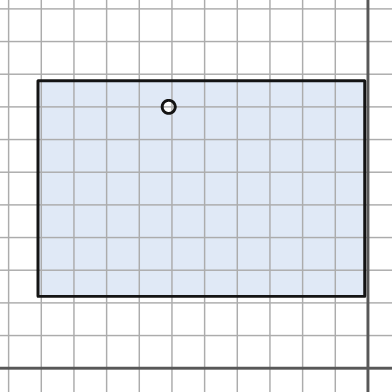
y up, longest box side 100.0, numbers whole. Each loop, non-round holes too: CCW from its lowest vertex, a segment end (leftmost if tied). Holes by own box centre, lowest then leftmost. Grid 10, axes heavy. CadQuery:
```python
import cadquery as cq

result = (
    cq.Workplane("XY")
    .moveTo(-101.0, 22.0)
    .lineTo(-1.0, 22.0)
    .lineTo(-1.0, 88.0)
    .lineTo(-101.0, 88.0)
    .close()
    .moveTo(-61.0, 80.0)
    .circle(2.0)
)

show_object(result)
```